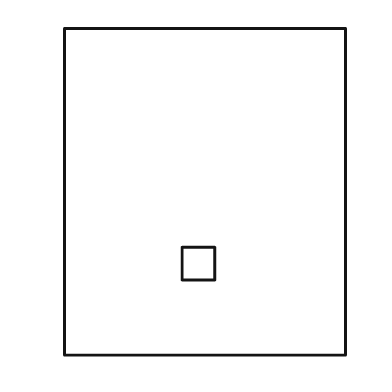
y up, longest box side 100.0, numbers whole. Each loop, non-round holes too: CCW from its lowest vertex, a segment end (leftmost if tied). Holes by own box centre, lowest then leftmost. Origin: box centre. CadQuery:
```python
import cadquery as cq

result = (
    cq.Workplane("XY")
    .moveTo(-43.0, -50.0)
    .lineTo(43.0, -50.0)
    .lineTo(43.0, 50.0)
    .lineTo(-43.0, 50.0)
    .close()
    .moveTo(-7.0, -27.0)
    .lineTo(3.0, -27.0)
    .lineTo(3.0, -17.0)
    .lineTo(-7.0, -17.0)
    .close()
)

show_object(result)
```